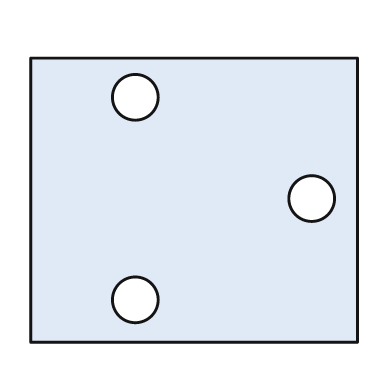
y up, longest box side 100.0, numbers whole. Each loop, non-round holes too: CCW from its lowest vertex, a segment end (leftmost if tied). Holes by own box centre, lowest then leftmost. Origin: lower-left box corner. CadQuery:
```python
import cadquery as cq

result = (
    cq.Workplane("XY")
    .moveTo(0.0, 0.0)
    .lineTo(100.0, 0.0)
    .lineTo(100.0, 87.0)
    .lineTo(0.0, 87.0)
    .close()
    .moveTo(32.0, 13.0)
    .circle(7.0)
    .moveTo(86.0, 44.0)
    .circle(7.0)
    .moveTo(32.0, 75.0)
    .circle(7.0)
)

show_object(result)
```